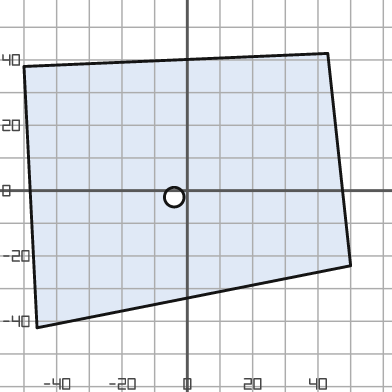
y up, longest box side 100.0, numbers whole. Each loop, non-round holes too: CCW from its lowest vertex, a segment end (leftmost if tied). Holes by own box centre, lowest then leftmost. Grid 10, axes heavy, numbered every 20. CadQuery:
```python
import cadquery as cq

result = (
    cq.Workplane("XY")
    .moveTo(-46.0, -42.0)
    .lineTo(50.0, -23.0)
    .lineTo(43.0, 42.0)
    .lineTo(-50.0, 38.0)
    .close()
    .moveTo(-4.0, -2.0)
    .circle(3.0)
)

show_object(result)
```